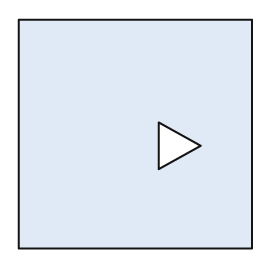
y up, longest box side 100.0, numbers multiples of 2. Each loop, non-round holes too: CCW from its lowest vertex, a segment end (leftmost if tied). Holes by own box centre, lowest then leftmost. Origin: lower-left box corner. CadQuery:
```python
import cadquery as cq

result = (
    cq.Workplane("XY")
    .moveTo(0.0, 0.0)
    .lineTo(100.0, 0.0)
    .lineTo(100.0, 98.0)
    .lineTo(0.0, 98.0)
    .close()
    .moveTo(60.0, 34.0)
    .lineTo(78.0, 44.0)
    .lineTo(60.0, 54.0)
    .close()
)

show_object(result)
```